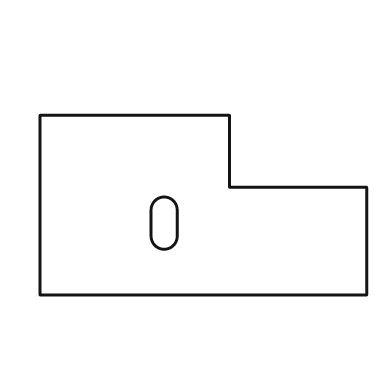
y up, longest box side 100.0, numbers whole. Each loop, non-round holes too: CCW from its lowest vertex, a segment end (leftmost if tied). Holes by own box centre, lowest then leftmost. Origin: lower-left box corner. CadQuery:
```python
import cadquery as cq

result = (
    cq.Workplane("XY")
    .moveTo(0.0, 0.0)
    .lineTo(100.0, 0.0)
    .lineTo(100.0, 33.0)
    .lineTo(58.0, 33.0)
    .lineTo(58.0, 55.0)
    .lineTo(0.0, 55.0)
    .close()
    .moveTo(34.0, 18.0)
    .threePointArc((38.0, 14.0), (42.0, 18.0))
    .lineTo(42.0, 26.0)
    .threePointArc((38.0, 30.0), (34.0, 26.0))
    .close()
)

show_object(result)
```